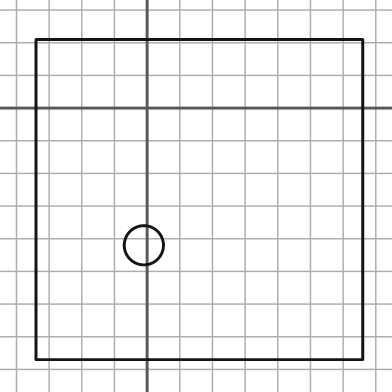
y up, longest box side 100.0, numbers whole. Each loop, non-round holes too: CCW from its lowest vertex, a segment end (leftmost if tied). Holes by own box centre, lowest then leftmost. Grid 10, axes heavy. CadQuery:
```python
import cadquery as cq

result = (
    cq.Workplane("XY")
    .moveTo(-34.0, -77.0)
    .lineTo(66.0, -77.0)
    .lineTo(66.0, 21.0)
    .lineTo(-34.0, 21.0)
    .close()
    .moveTo(-1.0, -42.0)
    .circle(6.0)
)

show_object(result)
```